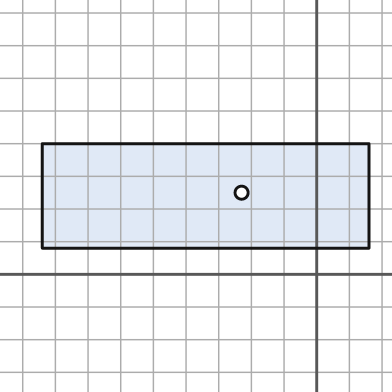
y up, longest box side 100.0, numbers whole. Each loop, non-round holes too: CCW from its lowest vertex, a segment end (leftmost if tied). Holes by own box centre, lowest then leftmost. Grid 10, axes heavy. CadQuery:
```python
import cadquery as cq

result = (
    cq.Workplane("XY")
    .moveTo(-84.0, 8.0)
    .lineTo(16.0, 8.0)
    .lineTo(16.0, 40.0)
    .lineTo(-84.0, 40.0)
    .close()
    .moveTo(-23.0, 25.0)
    .circle(2.0)
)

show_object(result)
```